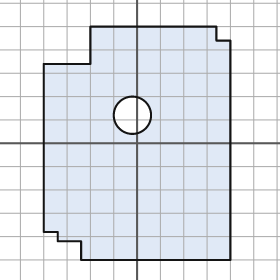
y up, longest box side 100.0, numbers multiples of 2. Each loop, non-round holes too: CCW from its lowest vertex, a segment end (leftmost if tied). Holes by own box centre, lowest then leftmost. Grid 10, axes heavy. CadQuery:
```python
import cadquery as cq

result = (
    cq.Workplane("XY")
    .moveTo(-24.0, -50.0)
    .lineTo(40.0, -50.0)
    .lineTo(40.0, 44.0)
    .lineTo(34.0, 44.0)
    .lineTo(34.0, 50.0)
    .lineTo(-20.0, 50.0)
    .lineTo(-20.0, 34.0)
    .lineTo(-40.0, 34.0)
    .lineTo(-40.0, -38.0)
    .lineTo(-34.0, -38.0)
    .lineTo(-34.0, -42.0)
    .lineTo(-24.0, -42.0)
    .close()
    .moveTo(-2.0, 12.0)
    .circle(8.0)
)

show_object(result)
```